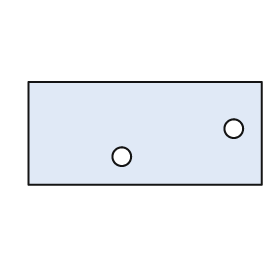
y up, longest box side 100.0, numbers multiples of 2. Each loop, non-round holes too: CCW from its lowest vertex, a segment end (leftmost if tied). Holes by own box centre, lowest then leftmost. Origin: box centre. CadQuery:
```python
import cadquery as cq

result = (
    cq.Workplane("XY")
    .moveTo(-50.0, -22.0)
    .lineTo(50.0, -22.0)
    .lineTo(50.0, 22.0)
    .lineTo(-50.0, 22.0)
    .close()
    .moveTo(-10.0, -10.0)
    .circle(4.0)
    .moveTo(38.0, 2.0)
    .circle(4.0)
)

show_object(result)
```